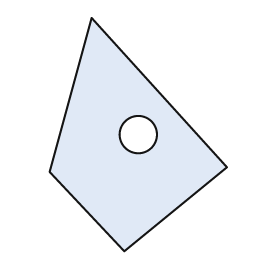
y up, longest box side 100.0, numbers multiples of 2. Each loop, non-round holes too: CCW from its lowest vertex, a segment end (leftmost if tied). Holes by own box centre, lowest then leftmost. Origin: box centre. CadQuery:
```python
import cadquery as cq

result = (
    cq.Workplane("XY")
    .moveTo(-6.0, -50.0)
    .lineTo(38.0, -14.0)
    .lineTo(-20.0, 50.0)
    .lineTo(-38.0, -16.0)
    .close()
    .moveTo(0.0, 0.0)
    .circle(8.0)
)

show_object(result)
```